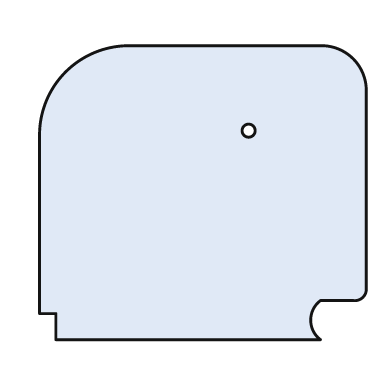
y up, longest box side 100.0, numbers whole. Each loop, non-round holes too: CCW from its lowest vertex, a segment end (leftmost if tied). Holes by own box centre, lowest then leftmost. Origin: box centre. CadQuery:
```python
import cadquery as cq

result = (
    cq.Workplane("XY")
    .moveTo(-45.0, -45.0)
    .lineTo(36.0, -45.0)
    .threePointArc((33.0, -39.0), (36.0, -33.0))
    .lineTo(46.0, -33.0)
    .threePointArc((49.0, -32.0), (50.0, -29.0))
    .lineTo(50.0, 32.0)
    .threePointArc((46.0, 41.0), (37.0, 45.0))
    .lineTo(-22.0, 45.0)
    .threePointArc((-42.0, 37.0), (-50.0, 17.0))
    .lineTo(-50.0, -37.0)
    .lineTo(-45.0, -37.0)
    .close()
    .moveTo(14.0, 19.0)
    .circle(2.0)
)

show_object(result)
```